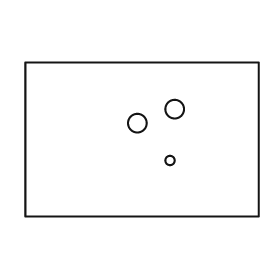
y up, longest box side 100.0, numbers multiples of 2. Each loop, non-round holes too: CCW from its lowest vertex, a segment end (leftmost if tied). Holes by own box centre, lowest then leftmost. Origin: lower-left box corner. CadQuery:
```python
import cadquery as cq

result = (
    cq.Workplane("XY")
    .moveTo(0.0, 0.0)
    .lineTo(100.0, 0.0)
    .lineTo(100.0, 66.0)
    .lineTo(0.0, 66.0)
    .close()
    .moveTo(62.0, 24.0)
    .circle(2.0)
    .moveTo(48.0, 40.0)
    .circle(4.0)
    .moveTo(64.0, 46.0)
    .circle(4.0)
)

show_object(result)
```